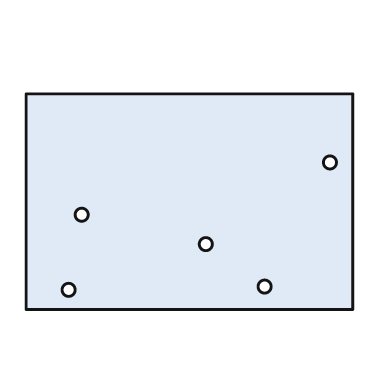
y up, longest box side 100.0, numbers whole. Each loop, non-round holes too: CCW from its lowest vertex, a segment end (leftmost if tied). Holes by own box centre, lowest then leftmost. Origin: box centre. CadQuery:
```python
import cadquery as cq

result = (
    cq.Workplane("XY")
    .moveTo(-50.0, -33.0)
    .lineTo(50.0, -33.0)
    .lineTo(50.0, 33.0)
    .lineTo(-50.0, 33.0)
    .close()
    .moveTo(-37.0, -27.0)
    .circle(2.0)
    .moveTo(23.0, -26.0)
    .circle(2.0)
    .moveTo(5.0, -13.0)
    .circle(2.0)
    .moveTo(-33.0, -4.0)
    .circle(2.0)
    .moveTo(43.0, 12.0)
    .circle(2.0)
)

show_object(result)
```